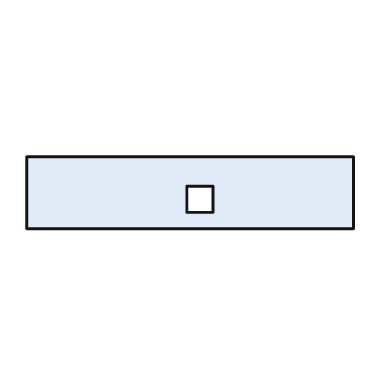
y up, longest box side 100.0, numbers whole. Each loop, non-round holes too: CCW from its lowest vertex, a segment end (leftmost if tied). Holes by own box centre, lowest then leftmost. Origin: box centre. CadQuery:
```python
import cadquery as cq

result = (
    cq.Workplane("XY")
    .moveTo(-50.0, -11.0)
    .lineTo(50.0, -11.0)
    .lineTo(50.0, 11.0)
    .lineTo(-50.0, 11.0)
    .close()
    .moveTo(-1.0, -6.0)
    .lineTo(7.0, -6.0)
    .lineTo(7.0, 2.0)
    .lineTo(-1.0, 2.0)
    .close()
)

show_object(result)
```